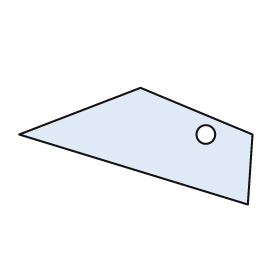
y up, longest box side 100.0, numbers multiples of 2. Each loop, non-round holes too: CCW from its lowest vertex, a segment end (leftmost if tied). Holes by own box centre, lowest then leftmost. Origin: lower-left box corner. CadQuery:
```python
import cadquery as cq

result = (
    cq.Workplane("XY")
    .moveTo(98.0, 0.0)
    .lineTo(100.0, 30.0)
    .lineTo(52.0, 50.0)
    .lineTo(0.0, 30.0)
    .close()
    .moveTo(80.0, 30.0)
    .circle(4.0)
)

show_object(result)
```